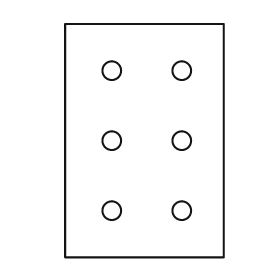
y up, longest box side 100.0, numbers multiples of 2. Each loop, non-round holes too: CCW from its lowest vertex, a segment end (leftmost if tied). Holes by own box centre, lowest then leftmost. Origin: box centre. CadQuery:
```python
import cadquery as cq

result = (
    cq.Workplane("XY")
    .moveTo(-34.0, -50.0)
    .lineTo(34.0, -50.0)
    .lineTo(34.0, 50.0)
    .lineTo(-34.0, 50.0)
    .close()
    .moveTo(-14.0, -30.0)
    .circle(4.0)
    .moveTo(16.0, -30.0)
    .circle(4.0)
    .moveTo(-14.0, 0.0)
    .circle(4.0)
    .moveTo(16.0, 0.0)
    .circle(4.0)
    .moveTo(-14.0, 30.0)
    .circle(4.0)
    .moveTo(16.0, 30.0)
    .circle(4.0)
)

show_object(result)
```